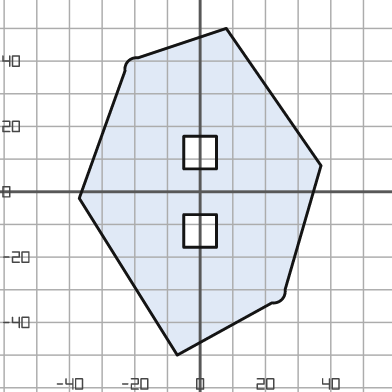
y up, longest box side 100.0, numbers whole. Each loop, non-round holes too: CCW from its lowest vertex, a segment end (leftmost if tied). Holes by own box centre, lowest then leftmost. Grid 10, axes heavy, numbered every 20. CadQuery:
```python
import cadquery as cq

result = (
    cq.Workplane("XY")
    .moveTo(-7.0, -50.0)
    .lineTo(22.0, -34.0)
    .threePointArc((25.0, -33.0), (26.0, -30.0))
    .lineTo(37.0, 8.0)
    .lineTo(8.0, 50.0)
    .lineTo(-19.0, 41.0)
    .threePointArc((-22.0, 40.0), (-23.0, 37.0))
    .lineTo(-37.0, -2.0)
    .close()
    .moveTo(-5.0, -17.0)
    .lineTo(5.0, -17.0)
    .lineTo(5.0, -7.0)
    .lineTo(-5.0, -7.0)
    .close()
    .moveTo(-5.0, 7.0)
    .lineTo(5.0, 7.0)
    .lineTo(5.0, 17.0)
    .lineTo(-5.0, 17.0)
    .close()
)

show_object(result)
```